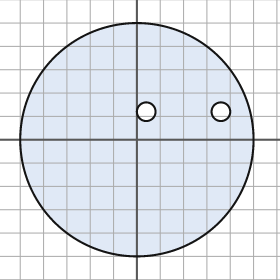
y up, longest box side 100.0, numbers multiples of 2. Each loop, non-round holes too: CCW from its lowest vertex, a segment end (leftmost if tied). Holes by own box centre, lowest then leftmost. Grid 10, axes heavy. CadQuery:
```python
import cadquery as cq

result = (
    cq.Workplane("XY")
    .moveTo(0.0, 0.0)
    .circle(50.0)
    .moveTo(4.0, 12.0)
    .circle(4.0)
    .moveTo(36.0, 12.0)
    .circle(4.0)
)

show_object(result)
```